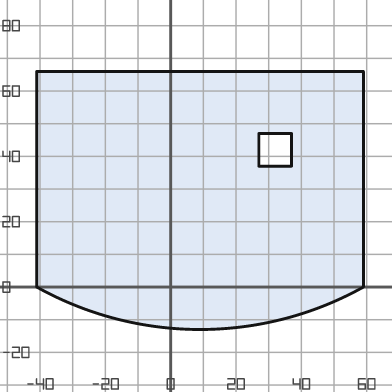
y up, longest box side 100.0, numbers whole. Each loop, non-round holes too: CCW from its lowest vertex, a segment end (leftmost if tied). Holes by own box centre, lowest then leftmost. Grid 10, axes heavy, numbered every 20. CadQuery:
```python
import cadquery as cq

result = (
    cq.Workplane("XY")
    .moveTo(-41.0, 0.0)
    .threePointArc((9.0, -13.0), (59.0, 0.0))
    .lineTo(59.0, 66.0)
    .lineTo(-41.0, 66.0)
    .close()
    .moveTo(27.0, 37.0)
    .lineTo(37.0, 37.0)
    .lineTo(37.0, 47.0)
    .lineTo(27.0, 47.0)
    .close()
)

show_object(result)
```